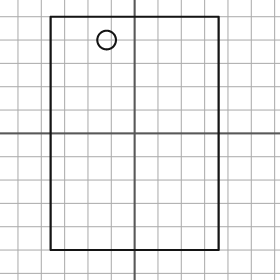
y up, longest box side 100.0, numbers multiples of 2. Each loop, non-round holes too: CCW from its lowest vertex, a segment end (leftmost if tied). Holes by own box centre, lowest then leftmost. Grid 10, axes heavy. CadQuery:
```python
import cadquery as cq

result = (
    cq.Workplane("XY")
    .moveTo(-36.0, -50.0)
    .lineTo(36.0, -50.0)
    .lineTo(36.0, 50.0)
    .lineTo(-36.0, 50.0)
    .close()
    .moveTo(-12.0, 40.0)
    .circle(4.0)
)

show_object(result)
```